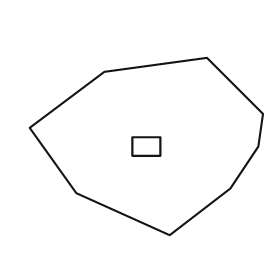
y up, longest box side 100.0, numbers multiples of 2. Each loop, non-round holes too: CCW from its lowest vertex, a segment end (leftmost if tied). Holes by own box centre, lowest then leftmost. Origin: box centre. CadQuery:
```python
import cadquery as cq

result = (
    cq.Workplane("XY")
    .moveTo(10.0, -38.0)
    .lineTo(36.0, -18.0)
    .lineTo(48.0, 0.0)
    .lineTo(50.0, 14.0)
    .lineTo(26.0, 38.0)
    .lineTo(-18.0, 32.0)
    .lineTo(-50.0, 8.0)
    .lineTo(-30.0, -20.0)
    .close()
    .moveTo(-6.0, -4.0)
    .lineTo(6.0, -4.0)
    .lineTo(6.0, 4.0)
    .lineTo(-6.0, 4.0)
    .close()
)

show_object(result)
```